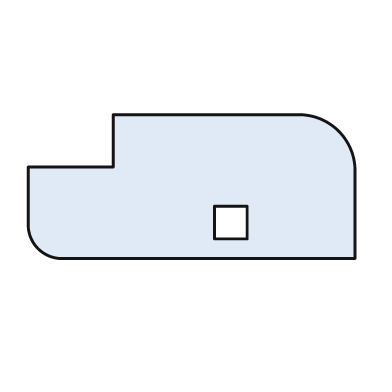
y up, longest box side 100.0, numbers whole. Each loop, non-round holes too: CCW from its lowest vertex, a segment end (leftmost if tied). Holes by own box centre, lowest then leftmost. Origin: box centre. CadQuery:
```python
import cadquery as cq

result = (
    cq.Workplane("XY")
    .moveTo(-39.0, -22.0)
    .lineTo(50.0, -22.0)
    .lineTo(50.0, 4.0)
    .threePointArc((45.0, 17.0), (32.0, 22.0))
    .lineTo(-24.0, 22.0)
    .lineTo(-24.0, 6.0)
    .lineTo(-50.0, 6.0)
    .lineTo(-50.0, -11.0)
    .threePointArc((-47.0, -19.0), (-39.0, -22.0))
    .close()
    .moveTo(7.0, -16.0)
    .lineTo(17.0, -16.0)
    .lineTo(17.0, -6.0)
    .lineTo(7.0, -6.0)
    .close()
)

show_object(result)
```